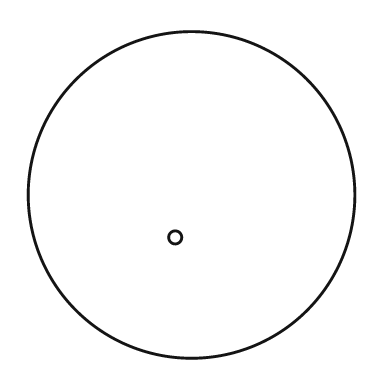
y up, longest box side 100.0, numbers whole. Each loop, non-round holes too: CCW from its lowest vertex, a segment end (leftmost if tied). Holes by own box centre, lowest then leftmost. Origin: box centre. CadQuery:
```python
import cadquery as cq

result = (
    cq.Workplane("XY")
    .moveTo(0.0, 0.0)
    .circle(50.0)
    .moveTo(-5.0, -13.0)
    .circle(2.0)
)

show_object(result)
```